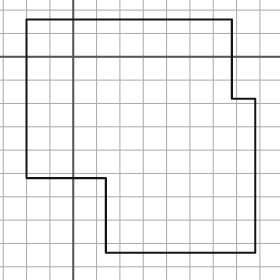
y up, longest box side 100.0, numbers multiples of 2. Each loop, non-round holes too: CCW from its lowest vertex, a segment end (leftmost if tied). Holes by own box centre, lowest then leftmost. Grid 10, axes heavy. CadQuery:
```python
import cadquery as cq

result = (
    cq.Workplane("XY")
    .moveTo(14.0, -84.0)
    .lineTo(78.0, -84.0)
    .lineTo(78.0, -18.0)
    .lineTo(68.0, -18.0)
    .lineTo(68.0, 16.0)
    .lineTo(-20.0, 16.0)
    .lineTo(-20.0, -52.0)
    .lineTo(14.0, -52.0)
    .close()
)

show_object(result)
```